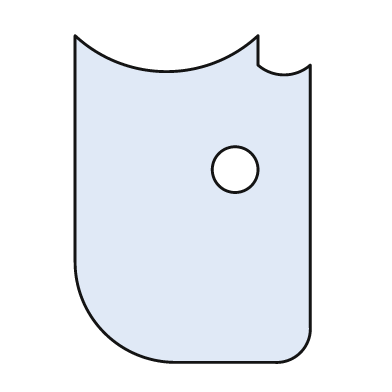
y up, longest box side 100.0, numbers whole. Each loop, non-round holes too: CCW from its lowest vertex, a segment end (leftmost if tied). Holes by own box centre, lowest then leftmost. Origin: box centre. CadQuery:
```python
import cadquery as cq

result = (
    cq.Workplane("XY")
    .moveTo(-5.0, -50.0)
    .lineTo(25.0, -50.0)
    .threePointArc((33.0, -47.0), (36.0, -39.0))
    .lineTo(36.0, 41.0)
    .threePointArc((28.0, 38.0), (20.0, 41.0))
    .lineTo(20.0, 50.0)
    .threePointArc((-8.0, 39.0), (-36.0, 50.0))
    .lineTo(-36.0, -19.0)
    .threePointArc((-27.0, -41.0), (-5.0, -50.0))
    .close()
    .moveTo(13.0, 9.0)
    .circle(7.0)
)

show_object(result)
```